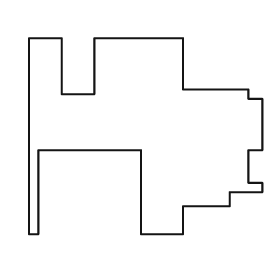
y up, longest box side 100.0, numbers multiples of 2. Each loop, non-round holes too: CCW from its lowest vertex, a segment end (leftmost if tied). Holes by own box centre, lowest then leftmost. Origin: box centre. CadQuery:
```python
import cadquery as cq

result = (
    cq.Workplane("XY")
    .moveTo(-50.0, -42.0)
    .lineTo(-46.0, -42.0)
    .lineTo(-46.0, -6.0)
    .lineTo(-2.0, -6.0)
    .lineTo(-2.0, -42.0)
    .lineTo(16.0, -42.0)
    .lineTo(16.0, -30.0)
    .lineTo(36.0, -30.0)
    .lineTo(36.0, -24.0)
    .lineTo(50.0, -24.0)
    .lineTo(50.0, -20.0)
    .lineTo(44.0, -20.0)
    .lineTo(44.0, -6.0)
    .lineTo(50.0, -6.0)
    .lineTo(50.0, 16.0)
    .lineTo(44.0, 16.0)
    .lineTo(44.0, 20.0)
    .lineTo(16.0, 20.0)
    .lineTo(16.0, 42.0)
    .lineTo(-22.0, 42.0)
    .lineTo(-22.0, 18.0)
    .lineTo(-36.0, 18.0)
    .lineTo(-36.0, 42.0)
    .lineTo(-50.0, 42.0)
    .close()
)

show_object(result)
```